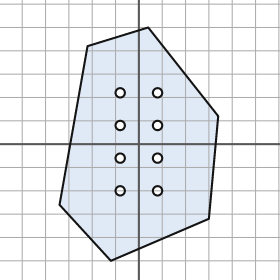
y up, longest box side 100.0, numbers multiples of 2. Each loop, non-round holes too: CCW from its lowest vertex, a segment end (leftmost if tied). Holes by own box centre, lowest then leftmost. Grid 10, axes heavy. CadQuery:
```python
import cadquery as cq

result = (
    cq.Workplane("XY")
    .moveTo(-12.0, -50.0)
    .lineTo(30.0, -32.0)
    .lineTo(34.0, 12.0)
    .lineTo(4.0, 50.0)
    .lineTo(-22.0, 42.0)
    .lineTo(-34.0, -26.0)
    .close()
    .moveTo(-8.0, -20.0)
    .circle(2.0)
    .moveTo(8.0, -20.0)
    .circle(2.0)
    .moveTo(-8.0, -6.0)
    .circle(2.0)
    .moveTo(8.0, -6.0)
    .circle(2.0)
    .moveTo(-8.0, 8.0)
    .circle(2.0)
    .moveTo(8.0, 8.0)
    .circle(2.0)
    .moveTo(-8.0, 22.0)
    .circle(2.0)
    .moveTo(8.0, 22.0)
    .circle(2.0)
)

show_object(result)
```